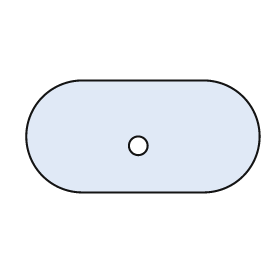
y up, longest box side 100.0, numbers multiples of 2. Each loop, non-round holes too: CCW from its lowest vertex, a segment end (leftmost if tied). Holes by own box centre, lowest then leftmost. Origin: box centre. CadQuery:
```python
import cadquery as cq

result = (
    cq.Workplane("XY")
    .moveTo(-26.0, -24.0)
    .lineTo(26.0, -24.0)
    .threePointArc((50.0, 0.0), (26.0, 24.0))
    .lineTo(-26.0, 24.0)
    .threePointArc((-50.0, 0.0), (-26.0, -24.0))
    .close()
    .moveTo(-2.0, -4.0)
    .circle(4.0)
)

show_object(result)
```